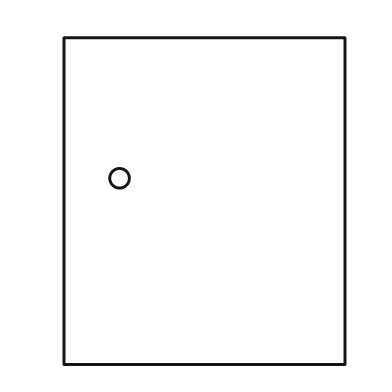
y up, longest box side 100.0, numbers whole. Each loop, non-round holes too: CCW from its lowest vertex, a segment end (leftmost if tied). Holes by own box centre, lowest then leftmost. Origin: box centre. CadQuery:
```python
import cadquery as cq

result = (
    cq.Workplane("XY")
    .moveTo(-43.0, -50.0)
    .lineTo(43.0, -50.0)
    .lineTo(43.0, 50.0)
    .lineTo(-43.0, 50.0)
    .close()
    .moveTo(-26.0, 7.0)
    .circle(3.0)
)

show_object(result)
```